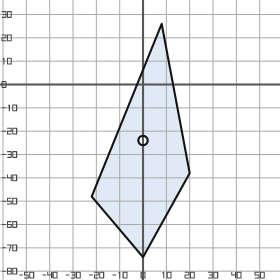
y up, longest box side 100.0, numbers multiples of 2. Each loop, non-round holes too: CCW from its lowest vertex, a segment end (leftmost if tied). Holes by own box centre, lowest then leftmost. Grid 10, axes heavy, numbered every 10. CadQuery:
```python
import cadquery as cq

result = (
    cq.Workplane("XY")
    .moveTo(0.0, -74.0)
    .lineTo(20.0, -38.0)
    .lineTo(8.0, 26.0)
    .lineTo(-22.0, -48.0)
    .close()
    .moveTo(0.0, -24.0)
    .circle(2.0)
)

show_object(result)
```